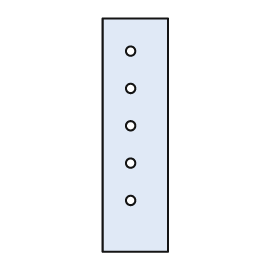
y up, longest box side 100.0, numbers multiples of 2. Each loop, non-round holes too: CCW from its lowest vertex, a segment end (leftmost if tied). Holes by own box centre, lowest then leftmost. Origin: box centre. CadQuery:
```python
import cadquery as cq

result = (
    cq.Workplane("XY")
    .moveTo(-14.0, -50.0)
    .lineTo(14.0, -50.0)
    .lineTo(14.0, 50.0)
    .lineTo(-14.0, 50.0)
    .close()
    .moveTo(-2.0, -28.0)
    .circle(2.0)
    .moveTo(-2.0, -12.0)
    .circle(2.0)
    .moveTo(-2.0, 4.0)
    .circle(2.0)
    .moveTo(-2.0, 20.0)
    .circle(2.0)
    .moveTo(-2.0, 36.0)
    .circle(2.0)
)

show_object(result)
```